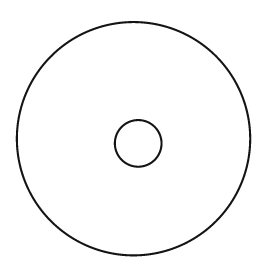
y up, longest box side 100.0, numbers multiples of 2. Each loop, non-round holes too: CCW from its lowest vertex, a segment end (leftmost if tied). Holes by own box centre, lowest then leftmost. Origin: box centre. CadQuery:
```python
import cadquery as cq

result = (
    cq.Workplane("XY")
    .moveTo(0.0, 0.0)
    .circle(50.0)
    .moveTo(2.0, -2.0)
    .circle(10.0)
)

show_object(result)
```